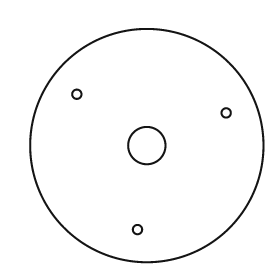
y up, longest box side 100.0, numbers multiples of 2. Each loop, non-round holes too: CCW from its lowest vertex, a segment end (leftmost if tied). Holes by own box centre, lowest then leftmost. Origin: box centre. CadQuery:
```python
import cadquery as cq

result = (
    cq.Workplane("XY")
    .moveTo(0.0, 0.0)
    .circle(50.0)
    .moveTo(-4.0, -36.0)
    .circle(2.0)
    .moveTo(0.0, 0.0)
    .circle(8.0)
    .moveTo(34.0, 14.0)
    .circle(2.0)
    .moveTo(-30.0, 22.0)
    .circle(2.0)
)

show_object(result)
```